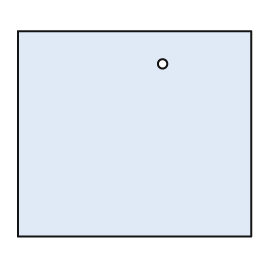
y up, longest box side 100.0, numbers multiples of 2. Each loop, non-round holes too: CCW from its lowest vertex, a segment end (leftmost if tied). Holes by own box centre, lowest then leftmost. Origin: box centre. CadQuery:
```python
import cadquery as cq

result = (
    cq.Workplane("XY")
    .moveTo(-50.0, -44.0)
    .lineTo(50.0, -44.0)
    .lineTo(50.0, 44.0)
    .lineTo(-50.0, 44.0)
    .close()
    .moveTo(12.0, 30.0)
    .circle(2.0)
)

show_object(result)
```